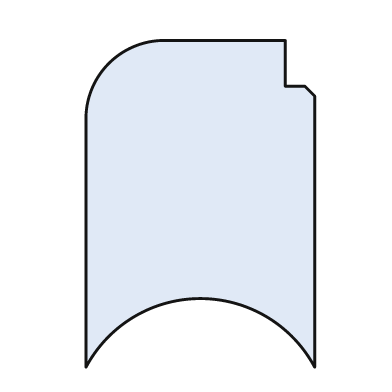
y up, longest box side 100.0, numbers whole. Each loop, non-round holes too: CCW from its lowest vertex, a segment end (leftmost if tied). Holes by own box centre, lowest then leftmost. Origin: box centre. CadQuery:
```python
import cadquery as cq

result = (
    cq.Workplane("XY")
    .moveTo(-35.0, -50.0)
    .threePointArc((0.0, -29.0), (35.0, -50.0))
    .lineTo(35.0, 33.0)
    .lineTo(32.0, 36.0)
    .lineTo(26.0, 36.0)
    .lineTo(26.0, 50.0)
    .lineTo(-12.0, 50.0)
    .threePointArc((-28.0, 43.0), (-35.0, 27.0))
    .close()
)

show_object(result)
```